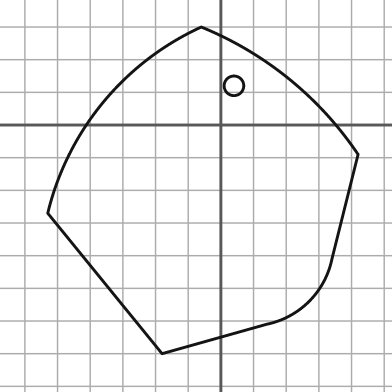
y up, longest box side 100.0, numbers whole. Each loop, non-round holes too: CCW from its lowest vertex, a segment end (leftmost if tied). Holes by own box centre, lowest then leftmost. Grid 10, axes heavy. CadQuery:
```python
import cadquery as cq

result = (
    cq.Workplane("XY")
    .moveTo(-18.0, -70.0)
    .lineTo(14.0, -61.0)
    .threePointArc((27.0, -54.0), (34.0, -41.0))
    .lineTo(42.0, -9.0)
    .threePointArc((21.0, 14.0), (-6.0, 30.0))
    .threePointArc((-36.0, 7.0), (-53.0, -27.0))
    .close()
    .moveTo(4.0, 12.0)
    .circle(3.0)
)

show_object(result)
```